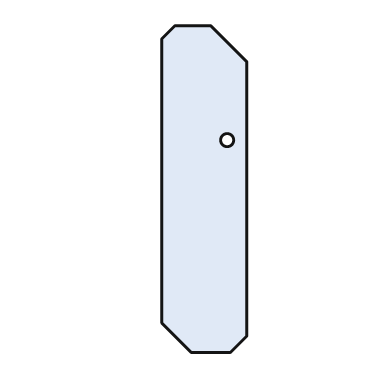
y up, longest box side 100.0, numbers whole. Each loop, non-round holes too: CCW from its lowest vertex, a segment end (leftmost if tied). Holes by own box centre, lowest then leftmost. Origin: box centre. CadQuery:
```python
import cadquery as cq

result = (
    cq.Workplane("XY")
    .moveTo(-4.0, -50.0)
    .lineTo(8.0, -50.0)
    .lineTo(13.0, -45.0)
    .lineTo(13.0, 39.0)
    .lineTo(2.0, 50.0)
    .lineTo(-9.0, 50.0)
    .lineTo(-13.0, 46.0)
    .lineTo(-13.0, -41.0)
    .close()
    .moveTo(7.0, 15.0)
    .circle(2.0)
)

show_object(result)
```